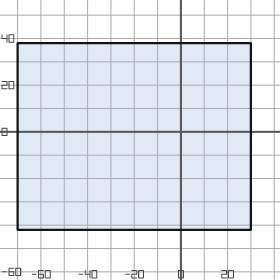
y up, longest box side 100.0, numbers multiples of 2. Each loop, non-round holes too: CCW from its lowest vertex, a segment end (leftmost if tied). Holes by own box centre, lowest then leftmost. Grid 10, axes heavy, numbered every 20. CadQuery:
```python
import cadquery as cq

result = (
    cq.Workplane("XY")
    .moveTo(-70.0, -42.0)
    .lineTo(30.0, -42.0)
    .lineTo(30.0, 38.0)
    .lineTo(-70.0, 38.0)
    .close()
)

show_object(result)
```